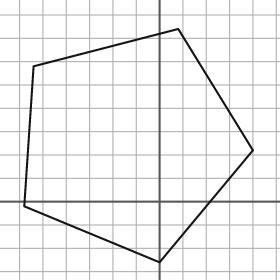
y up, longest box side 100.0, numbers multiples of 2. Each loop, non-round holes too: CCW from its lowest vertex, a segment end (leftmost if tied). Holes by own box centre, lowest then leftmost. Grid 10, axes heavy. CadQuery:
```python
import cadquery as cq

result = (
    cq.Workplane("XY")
    .moveTo(0.0, -26.0)
    .lineTo(40.0, 22.0)
    .lineTo(8.0, 74.0)
    .lineTo(-54.0, 58.0)
    .lineTo(-58.0, -2.0)
    .close()
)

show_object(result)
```